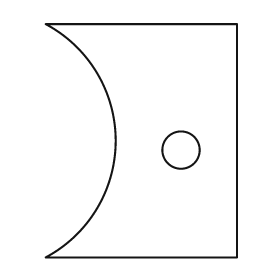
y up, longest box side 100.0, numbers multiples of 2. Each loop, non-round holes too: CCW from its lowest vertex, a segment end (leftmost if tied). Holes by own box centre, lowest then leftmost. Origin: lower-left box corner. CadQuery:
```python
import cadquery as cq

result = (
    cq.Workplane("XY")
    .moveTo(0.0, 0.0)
    .lineTo(82.0, 0.0)
    .lineTo(82.0, 100.0)
    .lineTo(0.0, 100.0)
    .threePointArc((30.0, 50.0), (0.0, 0.0))
    .close()
    .moveTo(58.0, 46.0)
    .circle(8.0)
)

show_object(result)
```